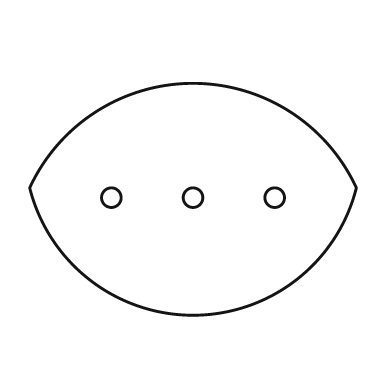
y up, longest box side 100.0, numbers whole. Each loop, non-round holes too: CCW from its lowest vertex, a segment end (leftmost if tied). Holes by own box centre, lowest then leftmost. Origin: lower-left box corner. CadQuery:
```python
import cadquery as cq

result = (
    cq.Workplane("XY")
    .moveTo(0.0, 39.0)
    .threePointArc((50.0, 0.0), (100.0, 39.0))
    .threePointArc((50.0, 71.0), (0.0, 39.0))
    .close()
    .moveTo(25.0, 36.0)
    .circle(3.0)
    .moveTo(50.0, 36.0)
    .circle(3.0)
    .moveTo(75.0, 36.0)
    .circle(3.0)
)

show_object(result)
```